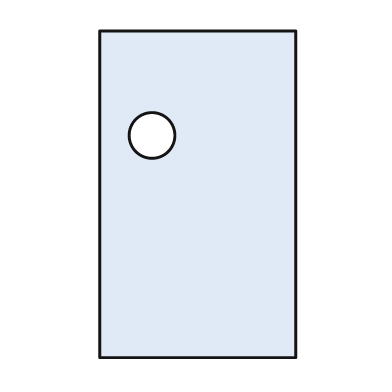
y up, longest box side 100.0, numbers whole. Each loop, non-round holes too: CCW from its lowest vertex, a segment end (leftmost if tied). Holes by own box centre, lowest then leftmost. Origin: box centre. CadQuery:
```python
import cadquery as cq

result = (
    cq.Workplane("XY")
    .moveTo(-30.0, -50.0)
    .lineTo(30.0, -50.0)
    .lineTo(30.0, 50.0)
    .lineTo(-30.0, 50.0)
    .close()
    .moveTo(-14.0, 18.0)
    .circle(7.0)
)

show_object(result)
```